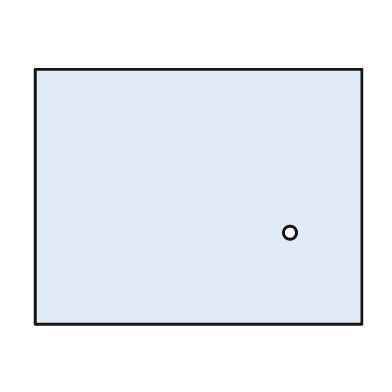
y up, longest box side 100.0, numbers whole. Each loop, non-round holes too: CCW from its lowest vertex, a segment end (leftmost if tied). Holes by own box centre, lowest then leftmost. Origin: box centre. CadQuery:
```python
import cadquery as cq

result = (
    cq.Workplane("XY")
    .moveTo(-50.0, -39.0)
    .lineTo(50.0, -39.0)
    .lineTo(50.0, 39.0)
    .lineTo(-50.0, 39.0)
    .close()
    .moveTo(28.0, -11.0)
    .circle(2.0)
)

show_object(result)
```